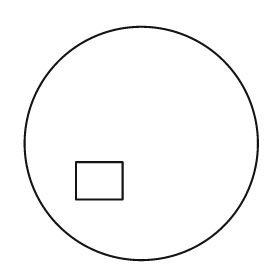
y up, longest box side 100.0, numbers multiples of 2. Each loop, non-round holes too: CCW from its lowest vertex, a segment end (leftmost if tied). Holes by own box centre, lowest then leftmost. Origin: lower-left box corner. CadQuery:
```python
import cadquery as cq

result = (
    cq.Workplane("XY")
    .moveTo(50.0, 50.0)
    .circle(50.0)
    .moveTo(22.0, 26.0)
    .lineTo(42.0, 26.0)
    .lineTo(42.0, 42.0)
    .lineTo(22.0, 42.0)
    .close()
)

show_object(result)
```